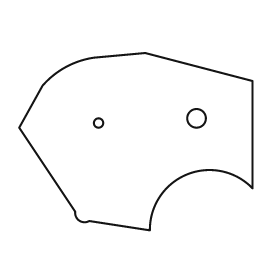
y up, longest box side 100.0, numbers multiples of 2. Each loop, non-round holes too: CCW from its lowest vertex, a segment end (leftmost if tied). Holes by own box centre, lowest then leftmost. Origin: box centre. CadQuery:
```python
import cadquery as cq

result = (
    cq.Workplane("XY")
    .moveTo(6.0, -38.0)
    .threePointArc((22.0, -14.0), (50.0, -20.0))
    .lineTo(50.0, 26.0)
    .lineTo(4.0, 38.0)
    .lineTo(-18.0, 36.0)
    .threePointArc((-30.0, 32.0), (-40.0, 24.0))
    .lineTo(-50.0, 6.0)
    .lineTo(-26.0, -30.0)
    .threePointArc((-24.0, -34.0), (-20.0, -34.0))
    .close()
    .moveTo(-16.0, 8.0)
    .circle(2.0)
    .moveTo(26.0, 10.0)
    .circle(4.0)
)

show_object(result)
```